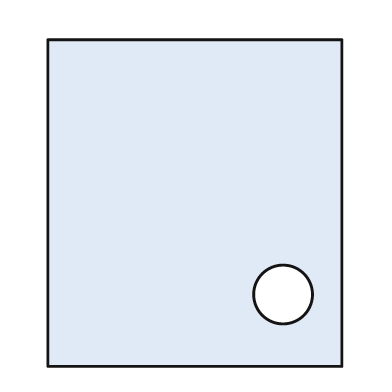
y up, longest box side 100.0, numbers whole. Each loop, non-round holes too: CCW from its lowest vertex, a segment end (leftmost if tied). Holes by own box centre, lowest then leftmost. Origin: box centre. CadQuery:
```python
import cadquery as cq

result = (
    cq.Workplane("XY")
    .moveTo(-45.0, -50.0)
    .lineTo(45.0, -50.0)
    .lineTo(45.0, 50.0)
    .lineTo(-45.0, 50.0)
    .close()
    .moveTo(27.0, -28.0)
    .circle(9.0)
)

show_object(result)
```